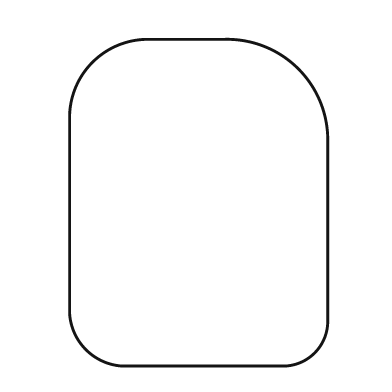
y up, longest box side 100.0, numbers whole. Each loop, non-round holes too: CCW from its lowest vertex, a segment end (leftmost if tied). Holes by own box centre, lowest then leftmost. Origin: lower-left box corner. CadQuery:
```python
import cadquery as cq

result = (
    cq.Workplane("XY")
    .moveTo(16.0, 0.0)
    .lineTo(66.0, 0.0)
    .threePointArc((75.0, 4.0), (79.0, 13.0))
    .lineTo(79.0, 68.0)
    .threePointArc((70.0, 91.0), (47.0, 100.0))
    .lineTo(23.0, 100.0)
    .threePointArc((7.0, 93.0), (0.0, 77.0))
    .lineTo(0.0, 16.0)
    .threePointArc((5.0, 5.0), (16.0, 0.0))
    .close()
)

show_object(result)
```